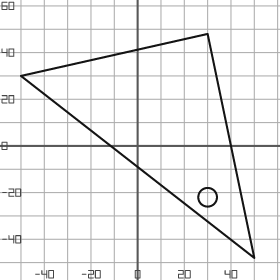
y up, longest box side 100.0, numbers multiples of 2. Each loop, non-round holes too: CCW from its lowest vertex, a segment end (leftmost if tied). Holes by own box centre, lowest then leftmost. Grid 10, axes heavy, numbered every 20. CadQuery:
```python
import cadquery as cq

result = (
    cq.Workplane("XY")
    .moveTo(50.0, -48.0)
    .lineTo(30.0, 48.0)
    .lineTo(-50.0, 30.0)
    .close()
    .moveTo(30.0, -22.0)
    .circle(4.0)
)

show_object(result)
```